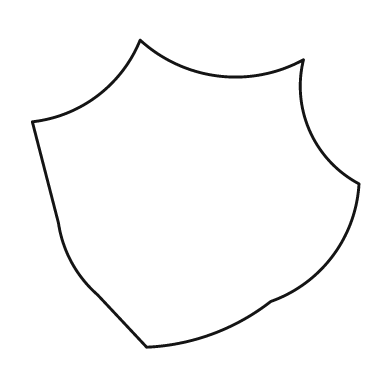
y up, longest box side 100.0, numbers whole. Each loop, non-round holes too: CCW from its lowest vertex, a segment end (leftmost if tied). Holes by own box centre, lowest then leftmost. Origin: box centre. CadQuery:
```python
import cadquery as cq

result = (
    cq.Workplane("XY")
    .moveTo(-15.0, -47.0)
    .threePointArc((5.0, -43.0), (23.0, -33.0))
    .threePointArc((42.0, -19.0), (50.0, 3.0))
    .threePointArc((35.0, 19.0), (33.0, 41.0))
    .threePointArc((7.0, 36.0), (-17.0, 47.0))
    .threePointArc((-30.0, 30.0), (-50.0, 22.0))
    .lineTo(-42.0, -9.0)
    .threePointArc((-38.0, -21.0), (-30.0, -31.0))
    .close()
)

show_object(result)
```